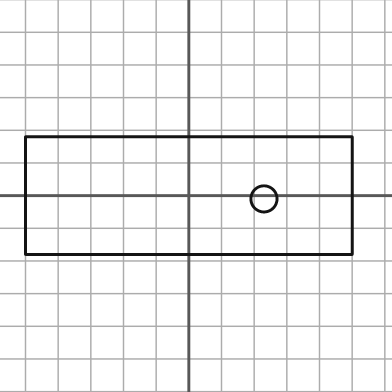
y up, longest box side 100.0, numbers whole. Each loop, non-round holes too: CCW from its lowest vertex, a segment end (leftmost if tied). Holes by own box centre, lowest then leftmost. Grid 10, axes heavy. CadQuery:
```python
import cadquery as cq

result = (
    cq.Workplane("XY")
    .moveTo(-50.0, -18.0)
    .lineTo(50.0, -18.0)
    .lineTo(50.0, 18.0)
    .lineTo(-50.0, 18.0)
    .close()
    .moveTo(23.0, -1.0)
    .circle(4.0)
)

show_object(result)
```